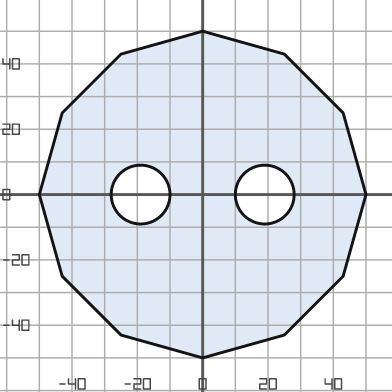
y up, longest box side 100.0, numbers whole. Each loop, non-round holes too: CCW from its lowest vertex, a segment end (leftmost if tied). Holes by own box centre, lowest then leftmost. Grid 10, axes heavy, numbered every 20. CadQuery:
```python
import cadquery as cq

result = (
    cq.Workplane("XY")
    .moveTo(0.0, -50.0)
    .lineTo(25.0, -43.0)
    .lineTo(43.0, -25.0)
    .lineTo(50.0, 0.0)
    .lineTo(43.0, 25.0)
    .lineTo(25.0, 43.0)
    .lineTo(0.0, 50.0)
    .lineTo(-25.0, 43.0)
    .lineTo(-43.0, 25.0)
    .lineTo(-50.0, 0.0)
    .lineTo(-43.0, -25.0)
    .lineTo(-25.0, -43.0)
    .close()
    .moveTo(-19.0, 0.0)
    .circle(9.0)
    .moveTo(19.0, 0.0)
    .circle(9.0)
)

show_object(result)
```